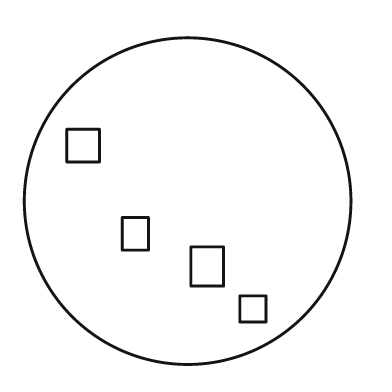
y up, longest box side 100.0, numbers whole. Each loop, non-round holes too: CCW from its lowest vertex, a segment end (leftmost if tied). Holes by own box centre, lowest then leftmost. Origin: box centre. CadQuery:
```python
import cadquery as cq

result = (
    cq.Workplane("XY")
    .moveTo(0.0, 0.0)
    .circle(50.0)
    .moveTo(16.0, -37.0)
    .lineTo(24.0, -37.0)
    .lineTo(24.0, -29.0)
    .lineTo(16.0, -29.0)
    .close()
    .moveTo(1.0, -26.0)
    .lineTo(11.0, -26.0)
    .lineTo(11.0, -14.0)
    .lineTo(1.0, -14.0)
    .close()
    .moveTo(-20.0, -15.0)
    .lineTo(-12.0, -15.0)
    .lineTo(-12.0, -5.0)
    .lineTo(-20.0, -5.0)
    .close()
    .moveTo(-37.0, 12.0)
    .lineTo(-27.0, 12.0)
    .lineTo(-27.0, 22.0)
    .lineTo(-37.0, 22.0)
    .close()
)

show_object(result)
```